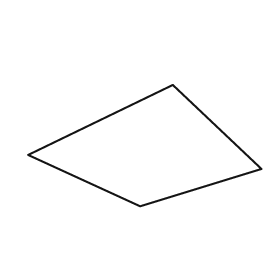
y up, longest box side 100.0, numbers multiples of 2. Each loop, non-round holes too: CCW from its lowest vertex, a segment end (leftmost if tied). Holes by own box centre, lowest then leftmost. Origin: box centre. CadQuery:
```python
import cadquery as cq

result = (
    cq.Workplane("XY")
    .moveTo(-2.0, -26.0)
    .lineTo(50.0, -10.0)
    .lineTo(12.0, 26.0)
    .lineTo(-50.0, -4.0)
    .close()
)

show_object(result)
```